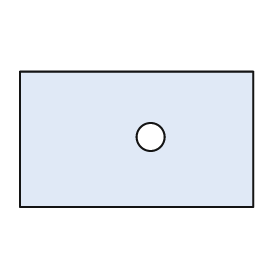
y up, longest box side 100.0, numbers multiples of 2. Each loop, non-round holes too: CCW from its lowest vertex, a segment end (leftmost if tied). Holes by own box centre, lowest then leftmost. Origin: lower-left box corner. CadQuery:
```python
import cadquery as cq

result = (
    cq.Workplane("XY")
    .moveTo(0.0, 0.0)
    .lineTo(100.0, 0.0)
    .lineTo(100.0, 58.0)
    .lineTo(0.0, 58.0)
    .close()
    .moveTo(56.0, 30.0)
    .circle(6.0)
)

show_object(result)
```